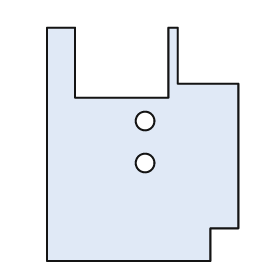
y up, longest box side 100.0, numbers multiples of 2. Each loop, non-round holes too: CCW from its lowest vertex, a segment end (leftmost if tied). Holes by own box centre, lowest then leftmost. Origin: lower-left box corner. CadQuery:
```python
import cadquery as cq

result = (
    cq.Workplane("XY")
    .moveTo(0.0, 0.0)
    .lineTo(70.0, 0.0)
    .lineTo(70.0, 14.0)
    .lineTo(82.0, 14.0)
    .lineTo(82.0, 76.0)
    .lineTo(56.0, 76.0)
    .lineTo(56.0, 100.0)
    .lineTo(52.0, 100.0)
    .lineTo(52.0, 70.0)
    .lineTo(12.0, 70.0)
    .lineTo(12.0, 100.0)
    .lineTo(0.0, 100.0)
    .close()
    .moveTo(42.0, 42.0)
    .circle(4.0)
    .moveTo(42.0, 60.0)
    .circle(4.0)
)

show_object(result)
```